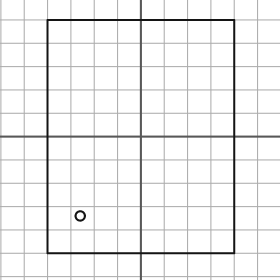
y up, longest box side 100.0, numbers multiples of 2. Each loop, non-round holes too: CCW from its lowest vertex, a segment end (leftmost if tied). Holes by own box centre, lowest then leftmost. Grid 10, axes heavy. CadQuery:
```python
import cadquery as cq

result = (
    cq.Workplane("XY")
    .moveTo(-40.0, -50.0)
    .lineTo(40.0, -50.0)
    .lineTo(40.0, 50.0)
    .lineTo(-40.0, 50.0)
    .close()
    .moveTo(-26.0, -34.0)
    .circle(2.0)
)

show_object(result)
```